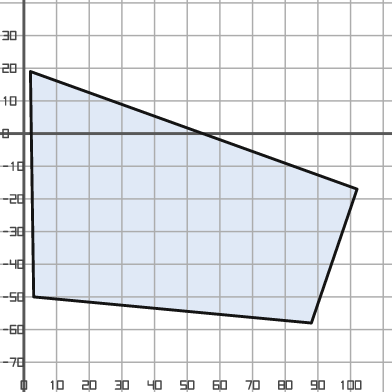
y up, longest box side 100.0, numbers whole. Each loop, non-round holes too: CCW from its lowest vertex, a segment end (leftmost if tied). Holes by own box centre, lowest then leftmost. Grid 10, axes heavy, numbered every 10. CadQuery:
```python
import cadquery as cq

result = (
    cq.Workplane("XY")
    .moveTo(88.0, -58.0)
    .lineTo(102.0, -17.0)
    .lineTo(2.0, 19.0)
    .lineTo(3.0, -50.0)
    .close()
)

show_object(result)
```